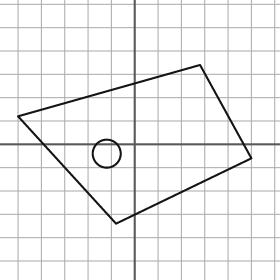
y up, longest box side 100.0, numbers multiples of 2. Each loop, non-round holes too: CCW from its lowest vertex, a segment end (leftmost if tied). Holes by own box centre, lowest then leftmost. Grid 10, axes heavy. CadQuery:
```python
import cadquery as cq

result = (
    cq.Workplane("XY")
    .moveTo(-8.0, -34.0)
    .lineTo(50.0, -6.0)
    .lineTo(28.0, 34.0)
    .lineTo(-50.0, 12.0)
    .close()
    .moveTo(-12.0, -4.0)
    .circle(6.0)
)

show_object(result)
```